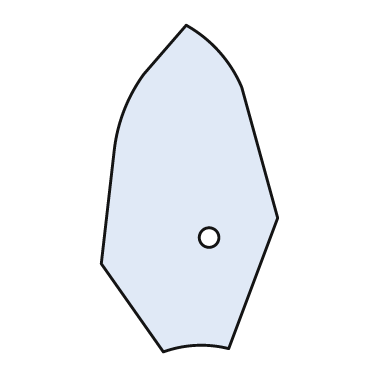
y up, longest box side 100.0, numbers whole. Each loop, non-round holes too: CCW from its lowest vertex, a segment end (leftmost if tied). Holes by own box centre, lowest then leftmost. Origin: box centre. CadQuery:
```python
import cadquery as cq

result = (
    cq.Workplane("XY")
    .moveTo(-8.0, -50.0)
    .threePointArc((2.0, -48.0), (12.0, -49.0))
    .lineTo(27.0, -9.0)
    .lineTo(16.0, 31.0)
    .threePointArc((9.0, 42.0), (-1.0, 50.0))
    .lineTo(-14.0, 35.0)
    .threePointArc((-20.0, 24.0), (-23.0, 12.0))
    .lineTo(-27.0, -23.0)
    .close()
    .moveTo(6.0, -15.0)
    .circle(3.0)
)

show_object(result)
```